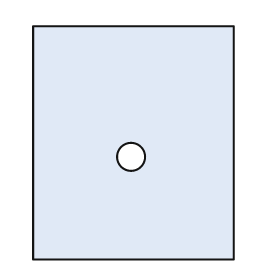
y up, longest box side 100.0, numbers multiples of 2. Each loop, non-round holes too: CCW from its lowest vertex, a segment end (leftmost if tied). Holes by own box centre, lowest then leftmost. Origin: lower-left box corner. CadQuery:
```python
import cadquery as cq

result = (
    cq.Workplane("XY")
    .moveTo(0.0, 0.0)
    .lineTo(86.0, 0.0)
    .lineTo(86.0, 100.0)
    .lineTo(0.0, 100.0)
    .close()
    .moveTo(42.0, 44.0)
    .circle(6.0)
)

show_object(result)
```